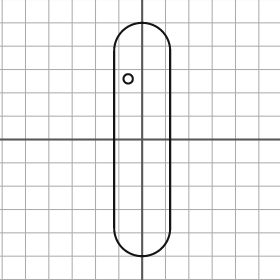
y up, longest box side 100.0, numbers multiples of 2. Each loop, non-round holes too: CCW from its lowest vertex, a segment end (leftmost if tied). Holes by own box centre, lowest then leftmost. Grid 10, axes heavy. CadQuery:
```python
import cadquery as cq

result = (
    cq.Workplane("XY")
    .moveTo(-12.0, -38.0)
    .threePointArc((0.0, -50.0), (12.0, -38.0))
    .lineTo(12.0, 38.0)
    .threePointArc((0.0, 50.0), (-12.0, 38.0))
    .close()
    .moveTo(-6.0, 26.0)
    .circle(2.0)
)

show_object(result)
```